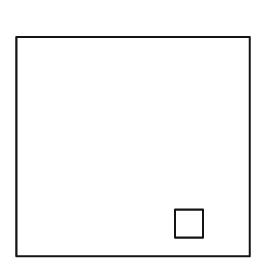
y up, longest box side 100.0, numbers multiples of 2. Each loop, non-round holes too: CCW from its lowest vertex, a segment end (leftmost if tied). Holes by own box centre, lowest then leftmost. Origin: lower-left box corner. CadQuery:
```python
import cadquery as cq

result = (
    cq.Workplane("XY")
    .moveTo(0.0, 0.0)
    .lineTo(100.0, 0.0)
    .lineTo(100.0, 94.0)
    .lineTo(0.0, 94.0)
    .close()
    .moveTo(68.0, 8.0)
    .lineTo(80.0, 8.0)
    .lineTo(80.0, 20.0)
    .lineTo(68.0, 20.0)
    .close()
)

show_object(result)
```